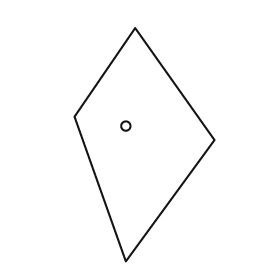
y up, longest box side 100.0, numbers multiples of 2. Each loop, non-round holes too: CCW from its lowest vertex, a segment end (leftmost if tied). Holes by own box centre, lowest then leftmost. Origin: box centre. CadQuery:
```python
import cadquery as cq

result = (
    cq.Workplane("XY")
    .moveTo(-8.0, -50.0)
    .lineTo(30.0, 2.0)
    .lineTo(-4.0, 50.0)
    .lineTo(-30.0, 12.0)
    .close()
    .moveTo(-8.0, 8.0)
    .circle(2.0)
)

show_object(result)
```